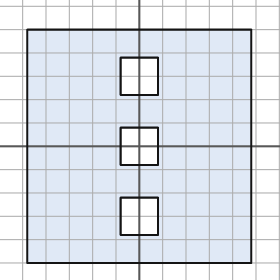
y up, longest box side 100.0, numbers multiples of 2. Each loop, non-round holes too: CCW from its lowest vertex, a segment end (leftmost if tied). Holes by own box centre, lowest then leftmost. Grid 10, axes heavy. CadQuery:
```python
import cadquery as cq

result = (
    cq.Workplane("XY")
    .moveTo(-48.0, -50.0)
    .lineTo(48.0, -50.0)
    .lineTo(48.0, 50.0)
    .lineTo(-48.0, 50.0)
    .close()
    .moveTo(-8.0, -38.0)
    .lineTo(8.0, -38.0)
    .lineTo(8.0, -22.0)
    .lineTo(-8.0, -22.0)
    .close()
    .moveTo(-8.0, -8.0)
    .lineTo(8.0, -8.0)
    .lineTo(8.0, 8.0)
    .lineTo(-8.0, 8.0)
    .close()
    .moveTo(-8.0, 22.0)
    .lineTo(8.0, 22.0)
    .lineTo(8.0, 38.0)
    .lineTo(-8.0, 38.0)
    .close()
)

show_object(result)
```